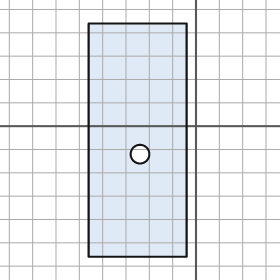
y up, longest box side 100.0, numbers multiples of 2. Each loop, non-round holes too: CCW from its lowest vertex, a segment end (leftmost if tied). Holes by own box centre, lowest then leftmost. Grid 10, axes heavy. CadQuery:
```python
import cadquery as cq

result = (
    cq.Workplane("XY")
    .moveTo(-46.0, -56.0)
    .lineTo(-4.0, -56.0)
    .lineTo(-4.0, 44.0)
    .lineTo(-46.0, 44.0)
    .close()
    .moveTo(-24.0, -12.0)
    .circle(4.0)
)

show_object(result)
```